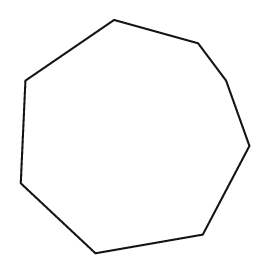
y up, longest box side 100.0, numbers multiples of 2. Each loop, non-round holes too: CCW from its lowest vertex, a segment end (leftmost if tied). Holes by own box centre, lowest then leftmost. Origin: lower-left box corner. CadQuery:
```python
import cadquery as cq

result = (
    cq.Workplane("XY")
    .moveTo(32.0, 0.0)
    .lineTo(78.0, 8.0)
    .lineTo(98.0, 46.0)
    .lineTo(88.0, 74.0)
    .lineTo(76.0, 90.0)
    .lineTo(40.0, 100.0)
    .lineTo(2.0, 74.0)
    .lineTo(0.0, 30.0)
    .close()
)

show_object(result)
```